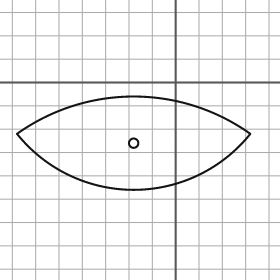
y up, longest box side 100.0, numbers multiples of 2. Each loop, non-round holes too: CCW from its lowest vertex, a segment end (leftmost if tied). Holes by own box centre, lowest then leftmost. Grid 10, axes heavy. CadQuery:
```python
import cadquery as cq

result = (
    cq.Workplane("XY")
    .moveTo(-68.0, -22.0)
    .threePointArc((-18.0, -46.0), (32.0, -22.0))
    .threePointArc((-18.0, -6.0), (-68.0, -22.0))
    .close()
    .moveTo(-18.0, -26.0)
    .circle(2.0)
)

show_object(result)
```